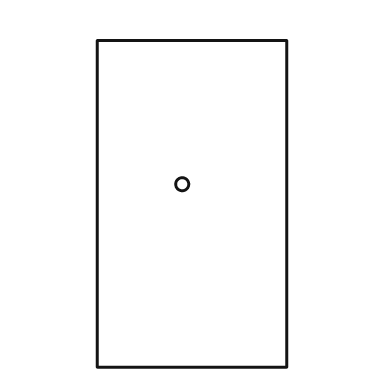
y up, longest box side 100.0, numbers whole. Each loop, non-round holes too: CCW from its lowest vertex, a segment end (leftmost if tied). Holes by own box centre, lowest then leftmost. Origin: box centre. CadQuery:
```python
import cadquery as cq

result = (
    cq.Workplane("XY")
    .moveTo(-29.0, -50.0)
    .lineTo(29.0, -50.0)
    .lineTo(29.0, 50.0)
    .lineTo(-29.0, 50.0)
    .close()
    .moveTo(-3.0, 6.0)
    .circle(2.0)
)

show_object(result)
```